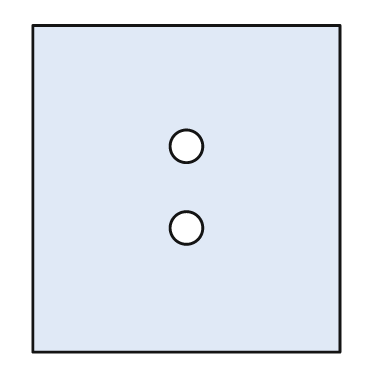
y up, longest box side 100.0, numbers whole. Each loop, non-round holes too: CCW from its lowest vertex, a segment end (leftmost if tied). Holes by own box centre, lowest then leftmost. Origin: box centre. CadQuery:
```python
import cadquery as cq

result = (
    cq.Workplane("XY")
    .moveTo(-47.0, -50.0)
    .lineTo(47.0, -50.0)
    .lineTo(47.0, 50.0)
    .lineTo(-47.0, 50.0)
    .close()
    .moveTo(0.0, -12.0)
    .circle(5.0)
    .moveTo(0.0, 13.0)
    .circle(5.0)
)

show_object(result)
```